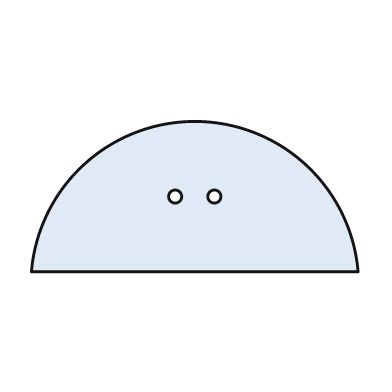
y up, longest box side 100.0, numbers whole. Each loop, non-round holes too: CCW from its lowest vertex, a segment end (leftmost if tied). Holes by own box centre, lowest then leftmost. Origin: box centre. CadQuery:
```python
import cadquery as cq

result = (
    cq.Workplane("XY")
    .moveTo(-50.0, -23.0)
    .lineTo(50.0, -23.0)
    .threePointArc((0.0, 23.0), (-50.0, -23.0))
    .close()
    .moveTo(-6.0, 0.0)
    .circle(2.0)
    .moveTo(6.0, 0.0)
    .circle(2.0)
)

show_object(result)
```